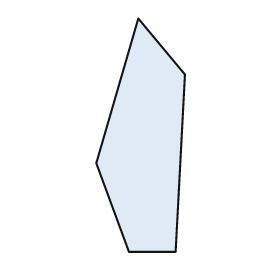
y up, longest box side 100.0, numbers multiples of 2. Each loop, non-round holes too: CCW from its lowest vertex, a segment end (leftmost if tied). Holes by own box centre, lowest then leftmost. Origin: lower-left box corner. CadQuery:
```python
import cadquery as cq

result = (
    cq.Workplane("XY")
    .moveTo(14.0, 0.0)
    .lineTo(34.0, 0.0)
    .lineTo(38.0, 76.0)
    .lineTo(18.0, 100.0)
    .lineTo(0.0, 38.0)
    .close()
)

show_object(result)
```